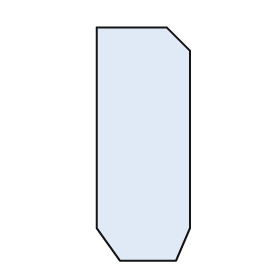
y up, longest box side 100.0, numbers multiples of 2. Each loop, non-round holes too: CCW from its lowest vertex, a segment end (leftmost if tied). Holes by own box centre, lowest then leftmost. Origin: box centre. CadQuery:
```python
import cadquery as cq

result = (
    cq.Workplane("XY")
    .moveTo(-10.0, -50.0)
    .lineTo(14.0, -50.0)
    .lineTo(20.0, -36.0)
    .lineTo(20.0, 40.0)
    .lineTo(10.0, 50.0)
    .lineTo(-20.0, 50.0)
    .lineTo(-20.0, -36.0)
    .close()
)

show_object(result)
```